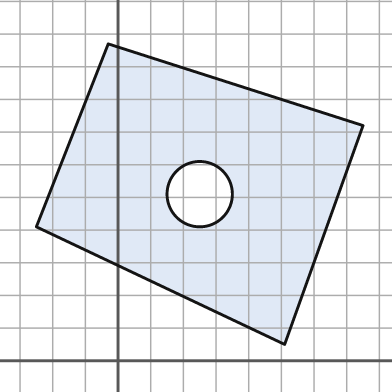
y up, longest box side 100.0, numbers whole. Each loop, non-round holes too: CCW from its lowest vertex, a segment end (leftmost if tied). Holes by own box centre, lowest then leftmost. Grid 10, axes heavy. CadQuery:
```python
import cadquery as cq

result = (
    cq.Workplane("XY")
    .moveTo(51.0, 5.0)
    .lineTo(75.0, 72.0)
    .lineTo(-3.0, 97.0)
    .lineTo(-25.0, 41.0)
    .close()
    .moveTo(25.0, 51.0)
    .circle(10.0)
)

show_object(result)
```